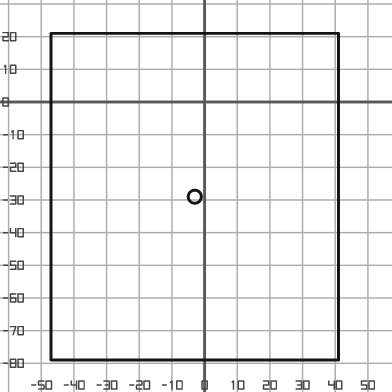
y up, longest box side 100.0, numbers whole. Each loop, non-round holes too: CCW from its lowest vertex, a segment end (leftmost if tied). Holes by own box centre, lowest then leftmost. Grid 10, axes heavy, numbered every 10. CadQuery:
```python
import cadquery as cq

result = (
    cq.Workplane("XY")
    .moveTo(-47.0, -79.0)
    .lineTo(41.0, -79.0)
    .lineTo(41.0, 21.0)
    .lineTo(-47.0, 21.0)
    .close()
    .moveTo(-3.0, -29.0)
    .circle(2.0)
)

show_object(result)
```